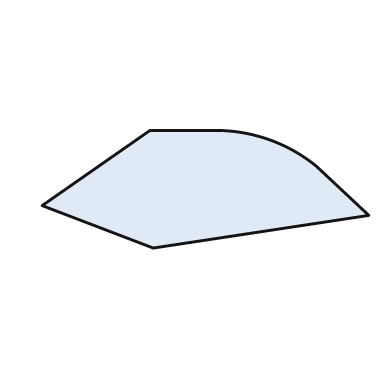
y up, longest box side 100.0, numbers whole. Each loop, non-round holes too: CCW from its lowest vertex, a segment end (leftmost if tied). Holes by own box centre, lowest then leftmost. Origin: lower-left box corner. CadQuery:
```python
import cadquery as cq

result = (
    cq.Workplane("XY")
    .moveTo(34.0, 0.0)
    .lineTo(100.0, 10.0)
    .lineTo(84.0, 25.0)
    .threePointArc((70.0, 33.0), (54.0, 36.0))
    .lineTo(33.0, 36.0)
    .lineTo(0.0, 13.0)
    .close()
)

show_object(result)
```